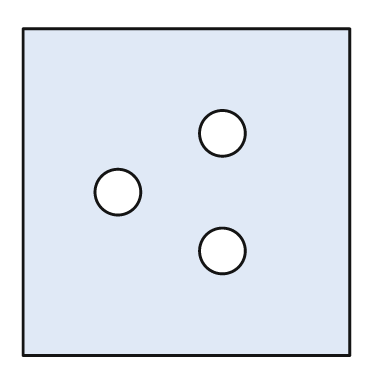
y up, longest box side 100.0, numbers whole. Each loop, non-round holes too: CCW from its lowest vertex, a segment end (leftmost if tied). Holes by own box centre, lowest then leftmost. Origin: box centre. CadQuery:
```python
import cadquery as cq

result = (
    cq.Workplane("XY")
    .moveTo(-50.0, -50.0)
    .lineTo(50.0, -50.0)
    .lineTo(50.0, 50.0)
    .lineTo(-50.0, 50.0)
    .close()
    .moveTo(11.0, -18.0)
    .circle(7.0)
    .moveTo(-21.0, 0.0)
    .circle(7.0)
    .moveTo(11.0, 18.0)
    .circle(7.0)
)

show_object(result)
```